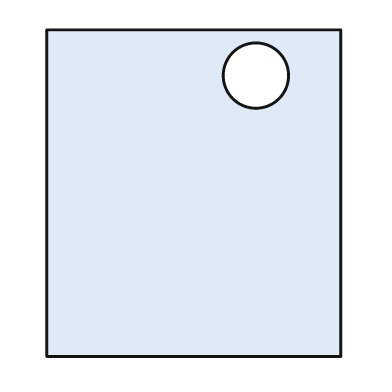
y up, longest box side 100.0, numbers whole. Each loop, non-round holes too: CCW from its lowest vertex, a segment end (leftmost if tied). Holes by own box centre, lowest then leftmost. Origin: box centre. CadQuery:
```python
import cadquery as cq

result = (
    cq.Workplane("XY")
    .moveTo(-45.0, -50.0)
    .lineTo(45.0, -50.0)
    .lineTo(45.0, 50.0)
    .lineTo(-45.0, 50.0)
    .close()
    .moveTo(19.0, 36.0)
    .circle(10.0)
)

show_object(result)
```